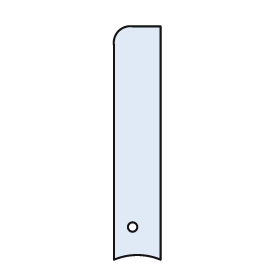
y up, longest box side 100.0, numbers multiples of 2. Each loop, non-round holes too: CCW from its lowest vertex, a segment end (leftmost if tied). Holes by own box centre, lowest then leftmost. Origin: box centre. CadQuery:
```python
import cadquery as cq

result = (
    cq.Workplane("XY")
    .moveTo(-10.0, -50.0)
    .threePointArc((0.0, -48.0), (10.0, -50.0))
    .lineTo(10.0, 50.0)
    .lineTo(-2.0, 50.0)
    .threePointArc((-8.0, 48.0), (-10.0, 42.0))
    .close()
    .moveTo(-2.0, -36.0)
    .circle(2.0)
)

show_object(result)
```